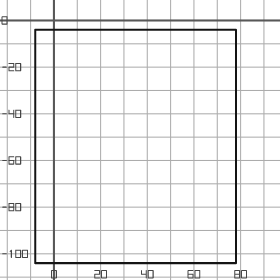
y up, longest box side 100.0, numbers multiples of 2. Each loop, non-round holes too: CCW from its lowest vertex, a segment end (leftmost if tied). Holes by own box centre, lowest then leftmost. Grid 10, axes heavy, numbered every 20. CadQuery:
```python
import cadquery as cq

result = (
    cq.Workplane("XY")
    .moveTo(-8.0, -104.0)
    .lineTo(78.0, -104.0)
    .lineTo(78.0, -4.0)
    .lineTo(-8.0, -4.0)
    .close()
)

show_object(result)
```